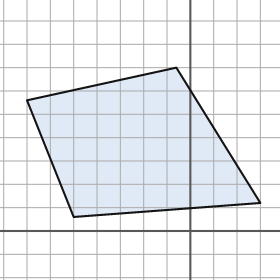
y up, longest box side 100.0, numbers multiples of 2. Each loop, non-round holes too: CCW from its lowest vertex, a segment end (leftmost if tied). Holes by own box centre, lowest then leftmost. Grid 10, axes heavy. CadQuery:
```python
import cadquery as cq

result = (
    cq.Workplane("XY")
    .moveTo(-50.0, 6.0)
    .lineTo(30.0, 12.0)
    .lineTo(-6.0, 70.0)
    .lineTo(-70.0, 56.0)
    .close()
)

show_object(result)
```